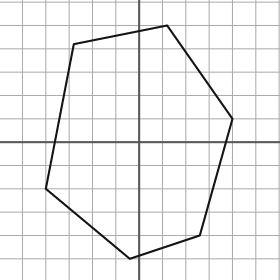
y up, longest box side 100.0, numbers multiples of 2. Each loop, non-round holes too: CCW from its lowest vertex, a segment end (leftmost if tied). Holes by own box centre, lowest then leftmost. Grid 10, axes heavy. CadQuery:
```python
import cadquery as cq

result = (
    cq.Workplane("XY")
    .moveTo(-4.0, -50.0)
    .lineTo(26.0, -40.0)
    .lineTo(40.0, 10.0)
    .lineTo(12.0, 50.0)
    .lineTo(-28.0, 42.0)
    .lineTo(-40.0, -20.0)
    .close()
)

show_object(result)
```